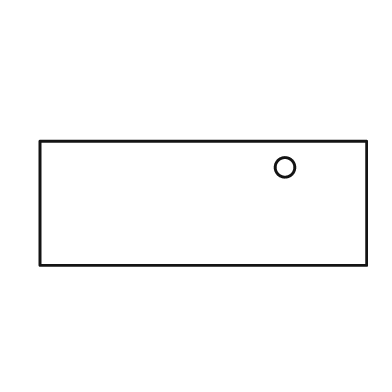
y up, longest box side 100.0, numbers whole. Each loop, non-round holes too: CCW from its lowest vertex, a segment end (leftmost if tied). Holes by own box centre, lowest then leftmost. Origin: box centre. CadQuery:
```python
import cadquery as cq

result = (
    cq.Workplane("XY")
    .moveTo(-50.0, -19.0)
    .lineTo(50.0, -19.0)
    .lineTo(50.0, 19.0)
    .lineTo(-50.0, 19.0)
    .close()
    .moveTo(25.0, 11.0)
    .circle(3.0)
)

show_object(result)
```